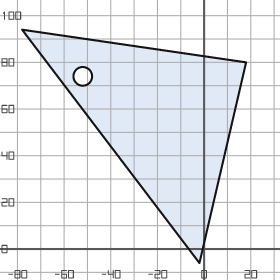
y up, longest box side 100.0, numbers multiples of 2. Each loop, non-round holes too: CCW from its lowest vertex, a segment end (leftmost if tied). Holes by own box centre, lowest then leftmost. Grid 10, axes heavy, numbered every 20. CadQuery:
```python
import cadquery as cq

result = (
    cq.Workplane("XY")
    .moveTo(-2.0, -6.0)
    .lineTo(18.0, 80.0)
    .lineTo(-78.0, 94.0)
    .close()
    .moveTo(-52.0, 74.0)
    .circle(4.0)
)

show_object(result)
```